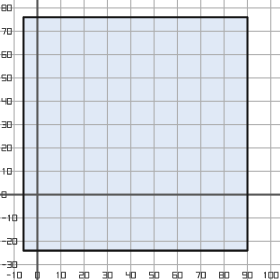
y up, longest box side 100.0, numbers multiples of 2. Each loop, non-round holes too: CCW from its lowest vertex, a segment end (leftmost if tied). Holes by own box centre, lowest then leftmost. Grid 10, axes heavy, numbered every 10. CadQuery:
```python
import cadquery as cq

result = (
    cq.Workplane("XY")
    .moveTo(-6.0, -24.0)
    .lineTo(90.0, -24.0)
    .lineTo(90.0, 76.0)
    .lineTo(-6.0, 76.0)
    .close()
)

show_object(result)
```